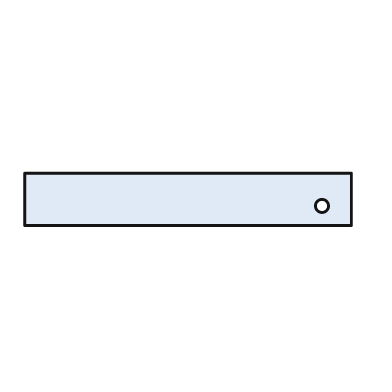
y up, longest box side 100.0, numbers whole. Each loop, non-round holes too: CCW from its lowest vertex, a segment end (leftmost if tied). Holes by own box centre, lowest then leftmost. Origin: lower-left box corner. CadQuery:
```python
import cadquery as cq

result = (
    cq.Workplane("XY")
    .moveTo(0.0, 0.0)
    .lineTo(100.0, 0.0)
    .lineTo(100.0, 16.0)
    .lineTo(0.0, 16.0)
    .close()
    .moveTo(91.0, 6.0)
    .circle(2.0)
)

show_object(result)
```